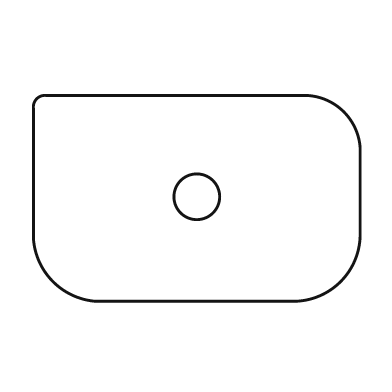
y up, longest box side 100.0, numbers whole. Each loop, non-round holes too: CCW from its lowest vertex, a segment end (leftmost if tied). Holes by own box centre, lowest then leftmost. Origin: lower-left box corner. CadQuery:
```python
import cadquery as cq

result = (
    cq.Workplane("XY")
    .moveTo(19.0, 0.0)
    .lineTo(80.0, 0.0)
    .threePointArc((94.0, 6.0), (100.0, 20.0))
    .lineTo(100.0, 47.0)
    .threePointArc((95.0, 58.0), (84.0, 63.0))
    .lineTo(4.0, 63.0)
    .threePointArc((1.0, 62.0), (0.0, 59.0))
    .lineTo(0.0, 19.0)
    .threePointArc((6.0, 6.0), (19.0, 0.0))
    .close()
    .moveTo(50.0, 32.0)
    .circle(7.0)
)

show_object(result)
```